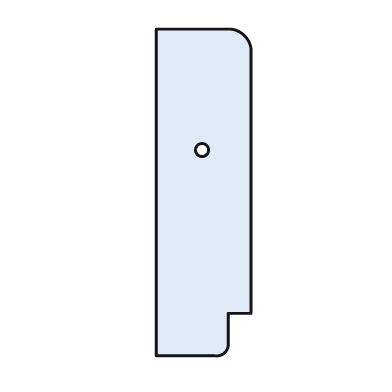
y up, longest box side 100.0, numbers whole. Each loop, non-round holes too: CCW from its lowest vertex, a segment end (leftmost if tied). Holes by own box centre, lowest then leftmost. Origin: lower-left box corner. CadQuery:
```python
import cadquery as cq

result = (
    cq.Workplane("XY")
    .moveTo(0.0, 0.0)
    .lineTo(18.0, 0.0)
    .threePointArc((21.0, 1.0), (22.0, 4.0))
    .lineTo(22.0, 13.0)
    .lineTo(29.0, 13.0)
    .lineTo(29.0, 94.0)
    .threePointArc((27.0, 98.0), (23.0, 100.0))
    .lineTo(0.0, 100.0)
    .close()
    .moveTo(14.0, 63.0)
    .circle(2.0)
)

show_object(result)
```